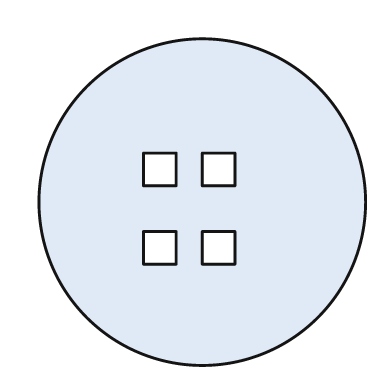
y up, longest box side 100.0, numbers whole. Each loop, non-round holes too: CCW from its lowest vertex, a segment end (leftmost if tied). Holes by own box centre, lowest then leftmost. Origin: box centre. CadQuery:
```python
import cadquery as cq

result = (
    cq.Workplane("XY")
    .moveTo(0.0, 0.0)
    .circle(50.0)
    .moveTo(-18.0, -19.0)
    .lineTo(-8.0, -19.0)
    .lineTo(-8.0, -9.0)
    .lineTo(-18.0, -9.0)
    .close()
    .moveTo(0.0, -19.0)
    .lineTo(10.0, -19.0)
    .lineTo(10.0, -9.0)
    .lineTo(0.0, -9.0)
    .close()
    .moveTo(-18.0, 5.0)
    .lineTo(-8.0, 5.0)
    .lineTo(-8.0, 15.0)
    .lineTo(-18.0, 15.0)
    .close()
    .moveTo(0.0, 5.0)
    .lineTo(10.0, 5.0)
    .lineTo(10.0, 15.0)
    .lineTo(0.0, 15.0)
    .close()
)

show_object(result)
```